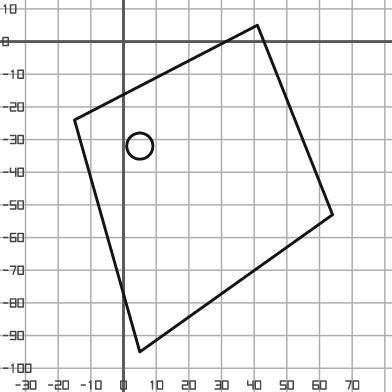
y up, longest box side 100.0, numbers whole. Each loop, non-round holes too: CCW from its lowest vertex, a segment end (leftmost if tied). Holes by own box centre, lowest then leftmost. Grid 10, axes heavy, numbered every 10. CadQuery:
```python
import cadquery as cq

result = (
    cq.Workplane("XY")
    .moveTo(5.0, -95.0)
    .lineTo(64.0, -53.0)
    .lineTo(41.0, 5.0)
    .lineTo(-15.0, -24.0)
    .close()
    .moveTo(5.0, -32.0)
    .circle(4.0)
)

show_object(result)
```